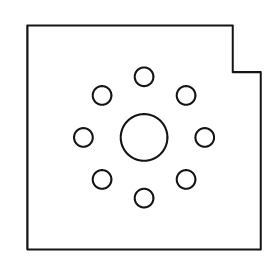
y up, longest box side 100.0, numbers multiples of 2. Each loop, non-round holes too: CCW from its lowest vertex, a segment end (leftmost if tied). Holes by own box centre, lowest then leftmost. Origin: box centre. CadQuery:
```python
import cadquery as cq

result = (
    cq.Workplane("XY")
    .moveTo(-50.0, -48.0)
    .lineTo(50.0, -48.0)
    .lineTo(50.0, 28.0)
    .lineTo(38.0, 28.0)
    .lineTo(38.0, 48.0)
    .lineTo(-50.0, 48.0)
    .close()
    .moveTo(0.0, -26.0)
    .circle(4.0)
    .moveTo(-18.0, -18.0)
    .circle(4.0)
    .moveTo(18.0, -18.0)
    .circle(4.0)
    .moveTo(-26.0, 0.0)
    .circle(4.0)
    .moveTo(0.0, 0.0)
    .circle(10.0)
    .moveTo(26.0, 0.0)
    .circle(4.0)
    .moveTo(-18.0, 18.0)
    .circle(4.0)
    .moveTo(18.0, 18.0)
    .circle(4.0)
    .moveTo(0.0, 26.0)
    .circle(4.0)
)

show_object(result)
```